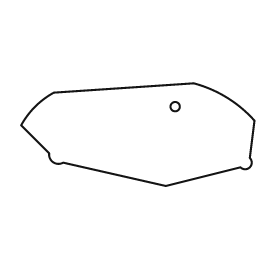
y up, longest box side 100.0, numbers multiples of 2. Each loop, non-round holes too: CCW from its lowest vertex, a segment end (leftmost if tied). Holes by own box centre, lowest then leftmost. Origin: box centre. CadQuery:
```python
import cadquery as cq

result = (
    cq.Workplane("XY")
    .moveTo(12.0, -22.0)
    .lineTo(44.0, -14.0)
    .threePointArc((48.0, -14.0), (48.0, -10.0))
    .lineTo(50.0, 6.0)
    .threePointArc((38.0, 16.0), (24.0, 22.0))
    .lineTo(-36.0, 18.0)
    .threePointArc((-44.0, 12.0), (-50.0, 4.0))
    .lineTo(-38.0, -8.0)
    .threePointArc((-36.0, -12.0), (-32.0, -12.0))
    .close()
    .moveTo(16.0, 12.0)
    .circle(2.0)
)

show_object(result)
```